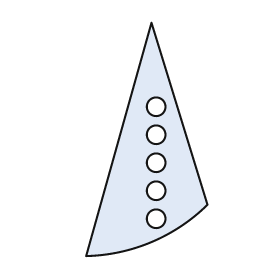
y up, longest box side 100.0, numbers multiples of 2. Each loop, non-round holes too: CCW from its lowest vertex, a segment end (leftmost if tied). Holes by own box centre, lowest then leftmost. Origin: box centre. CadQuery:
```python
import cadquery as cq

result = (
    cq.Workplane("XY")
    .moveTo(-26.0, -50.0)
    .threePointArc((2.0, -44.0), (26.0, -28.0))
    .lineTo(2.0, 50.0)
    .close()
    .moveTo(4.0, -34.0)
    .circle(4.0)
    .moveTo(4.0, -22.0)
    .circle(4.0)
    .moveTo(4.0, -10.0)
    .circle(4.0)
    .moveTo(4.0, 2.0)
    .circle(4.0)
    .moveTo(4.0, 14.0)
    .circle(4.0)
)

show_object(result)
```